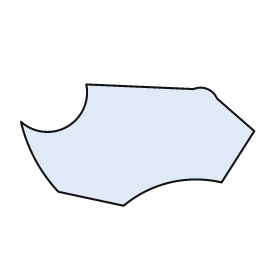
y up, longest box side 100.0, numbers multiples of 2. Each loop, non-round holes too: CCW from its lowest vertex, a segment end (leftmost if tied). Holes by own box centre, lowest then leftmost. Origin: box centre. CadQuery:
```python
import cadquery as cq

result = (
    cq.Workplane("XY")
    .moveTo(-6.0, -26.0)
    .threePointArc((14.0, -16.0), (36.0, -16.0))
    .lineTo(50.0, 6.0)
    .lineTo(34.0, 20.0)
    .threePointArc((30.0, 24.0), (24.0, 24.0))
    .lineTo(-22.0, 26.0)
    .threePointArc((-30.0, 8.0), (-50.0, 10.0))
    .threePointArc((-44.0, -6.0), (-34.0, -20.0))
    .close()
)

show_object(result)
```